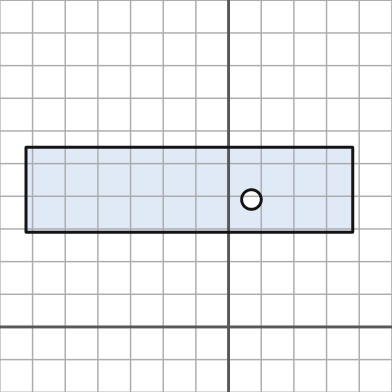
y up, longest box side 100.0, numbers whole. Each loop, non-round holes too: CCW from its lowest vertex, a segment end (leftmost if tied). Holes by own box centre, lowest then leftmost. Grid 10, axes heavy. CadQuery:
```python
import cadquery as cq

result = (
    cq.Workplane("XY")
    .moveTo(-62.0, 29.0)
    .lineTo(38.0, 29.0)
    .lineTo(38.0, 55.0)
    .lineTo(-62.0, 55.0)
    .close()
    .moveTo(7.0, 39.0)
    .circle(3.0)
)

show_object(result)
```